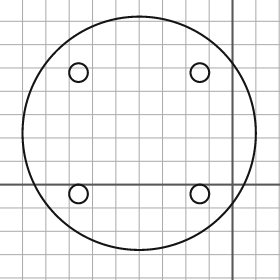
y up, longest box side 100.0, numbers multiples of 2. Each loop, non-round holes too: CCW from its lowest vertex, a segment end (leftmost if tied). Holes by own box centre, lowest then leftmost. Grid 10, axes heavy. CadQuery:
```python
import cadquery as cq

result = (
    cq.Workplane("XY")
    .moveTo(-40.0, 22.0)
    .circle(50.0)
    .moveTo(-66.0, -4.0)
    .circle(4.0)
    .moveTo(-14.0, -4.0)
    .circle(4.0)
    .moveTo(-66.0, 48.0)
    .circle(4.0)
    .moveTo(-14.0, 48.0)
    .circle(4.0)
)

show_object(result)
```